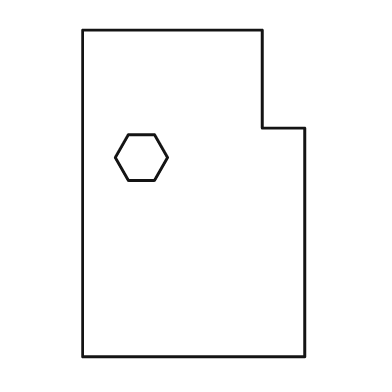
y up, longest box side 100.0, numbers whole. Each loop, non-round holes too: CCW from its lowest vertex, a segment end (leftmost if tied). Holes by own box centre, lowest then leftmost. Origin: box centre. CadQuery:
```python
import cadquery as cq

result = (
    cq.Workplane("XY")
    .moveTo(-34.0, -50.0)
    .lineTo(34.0, -50.0)
    .lineTo(34.0, 20.0)
    .lineTo(21.0, 20.0)
    .lineTo(21.0, 50.0)
    .lineTo(-34.0, 50.0)
    .close()
    .moveTo(-20.0, 4.0)
    .lineTo(-12.0, 4.0)
    .lineTo(-8.0, 11.0)
    .lineTo(-12.0, 18.0)
    .lineTo(-20.0, 18.0)
    .lineTo(-24.0, 11.0)
    .close()
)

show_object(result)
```